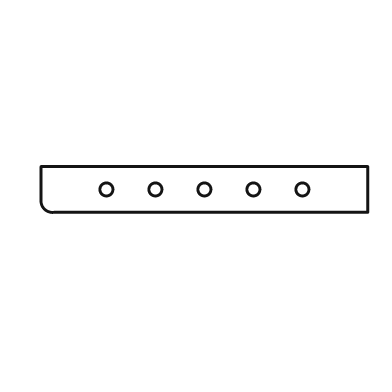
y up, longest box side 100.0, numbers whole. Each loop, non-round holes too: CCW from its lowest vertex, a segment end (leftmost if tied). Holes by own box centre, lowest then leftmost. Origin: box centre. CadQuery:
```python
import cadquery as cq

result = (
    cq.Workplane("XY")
    .moveTo(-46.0, -7.0)
    .lineTo(50.0, -7.0)
    .lineTo(50.0, 7.0)
    .lineTo(-50.0, 7.0)
    .lineTo(-50.0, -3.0)
    .threePointArc((-49.0, -6.0), (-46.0, -7.0))
    .close()
    .moveTo(-30.0, 0.0)
    .circle(2.0)
    .moveTo(-15.0, 0.0)
    .circle(2.0)
    .moveTo(0.0, 0.0)
    .circle(2.0)
    .moveTo(15.0, 0.0)
    .circle(2.0)
    .moveTo(30.0, 0.0)
    .circle(2.0)
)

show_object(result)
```